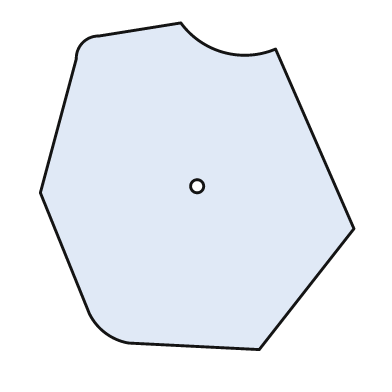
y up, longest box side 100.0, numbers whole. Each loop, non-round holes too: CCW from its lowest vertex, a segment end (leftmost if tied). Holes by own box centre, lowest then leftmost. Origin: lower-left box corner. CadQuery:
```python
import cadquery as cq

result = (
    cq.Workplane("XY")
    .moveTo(67.0, 0.0)
    .lineTo(96.0, 37.0)
    .lineTo(72.0, 92.0)
    .threePointArc((56.0, 91.0), (43.0, 100.0))
    .lineTo(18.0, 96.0)
    .threePointArc((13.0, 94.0), (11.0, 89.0))
    .lineTo(0.0, 48.0)
    .lineTo(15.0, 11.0)
    .threePointArc((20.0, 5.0), (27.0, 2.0))
    .close()
    .moveTo(48.0, 50.0)
    .circle(2.0)
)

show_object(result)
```